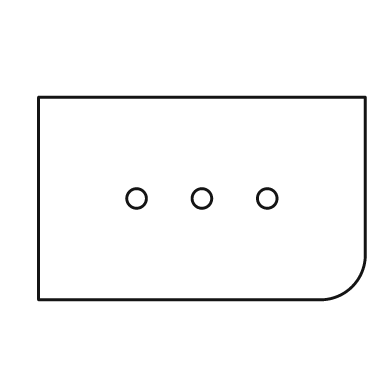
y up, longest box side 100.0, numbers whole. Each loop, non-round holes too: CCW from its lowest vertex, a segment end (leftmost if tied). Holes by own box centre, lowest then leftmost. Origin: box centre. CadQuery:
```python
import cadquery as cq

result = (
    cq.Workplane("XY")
    .moveTo(-50.0, -31.0)
    .lineTo(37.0, -31.0)
    .threePointArc((46.0, -27.0), (50.0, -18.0))
    .lineTo(50.0, 31.0)
    .lineTo(-50.0, 31.0)
    .close()
    .moveTo(-20.0, 0.0)
    .circle(3.0)
    .moveTo(0.0, 0.0)
    .circle(3.0)
    .moveTo(20.0, 0.0)
    .circle(3.0)
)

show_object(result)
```